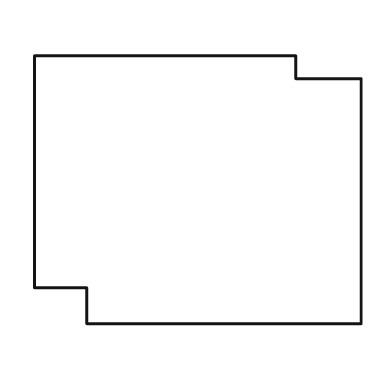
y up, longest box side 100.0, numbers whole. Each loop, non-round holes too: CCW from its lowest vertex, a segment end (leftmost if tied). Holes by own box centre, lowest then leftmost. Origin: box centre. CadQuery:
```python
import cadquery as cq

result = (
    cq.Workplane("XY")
    .moveTo(-34.0, -41.0)
    .lineTo(50.0, -41.0)
    .lineTo(50.0, 34.0)
    .lineTo(30.0, 34.0)
    .lineTo(30.0, 41.0)
    .lineTo(-50.0, 41.0)
    .lineTo(-50.0, -30.0)
    .lineTo(-34.0, -30.0)
    .close()
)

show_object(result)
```